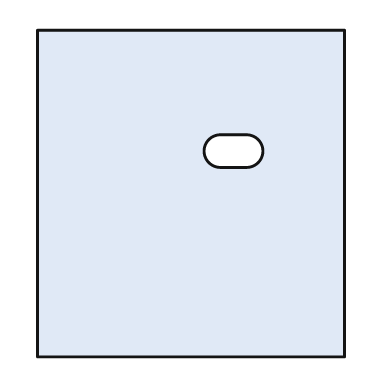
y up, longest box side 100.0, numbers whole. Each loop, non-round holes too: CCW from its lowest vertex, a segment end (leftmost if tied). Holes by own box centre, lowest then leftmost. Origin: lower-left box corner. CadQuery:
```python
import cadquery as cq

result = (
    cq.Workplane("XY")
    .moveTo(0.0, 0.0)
    .lineTo(94.0, 0.0)
    .lineTo(94.0, 100.0)
    .lineTo(0.0, 100.0)
    .close()
    .moveTo(56.0, 58.0)
    .lineTo(64.0, 58.0)
    .threePointArc((69.0, 63.0), (64.0, 68.0))
    .lineTo(56.0, 68.0)
    .threePointArc((51.0, 63.0), (56.0, 58.0))
    .close()
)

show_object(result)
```